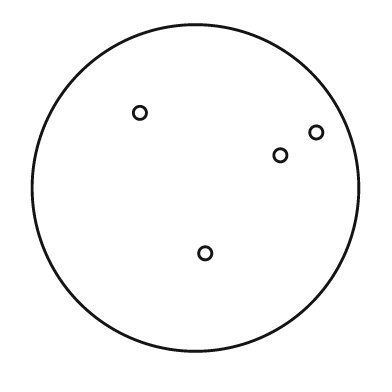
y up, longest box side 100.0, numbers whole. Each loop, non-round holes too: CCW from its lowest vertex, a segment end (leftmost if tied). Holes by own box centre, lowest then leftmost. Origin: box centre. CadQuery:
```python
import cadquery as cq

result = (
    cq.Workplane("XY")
    .moveTo(0.0, 0.0)
    .circle(50.0)
    .moveTo(3.0, -20.0)
    .circle(2.0)
    .moveTo(26.0, 10.0)
    .circle(2.0)
    .moveTo(37.0, 17.0)
    .circle(2.0)
    .moveTo(-17.0, 23.0)
    .circle(2.0)
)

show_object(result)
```